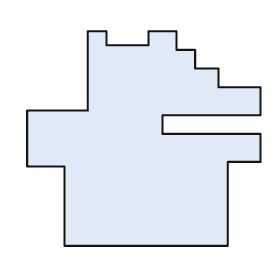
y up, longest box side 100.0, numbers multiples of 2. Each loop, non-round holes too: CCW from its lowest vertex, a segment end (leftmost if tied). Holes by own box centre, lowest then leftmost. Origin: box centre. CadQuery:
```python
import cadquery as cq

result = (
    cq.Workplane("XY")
    .moveTo(-34.0, -46.0)
    .lineTo(36.0, -46.0)
    .lineTo(36.0, -10.0)
    .lineTo(50.0, -10.0)
    .lineTo(50.0, 2.0)
    .lineTo(8.0, 2.0)
    .lineTo(8.0, 10.0)
    .lineTo(50.0, 10.0)
    .lineTo(50.0, 22.0)
    .lineTo(32.0, 22.0)
    .lineTo(32.0, 30.0)
    .lineTo(22.0, 30.0)
    .lineTo(22.0, 38.0)
    .lineTo(14.0, 38.0)
    .lineTo(14.0, 46.0)
    .lineTo(2.0, 46.0)
    .lineTo(2.0, 40.0)
    .lineTo(-16.0, 40.0)
    .lineTo(-16.0, 46.0)
    .lineTo(-24.0, 46.0)
    .lineTo(-24.0, 12.0)
    .lineTo(-50.0, 12.0)
    .lineTo(-50.0, -12.0)
    .lineTo(-34.0, -12.0)
    .close()
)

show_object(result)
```